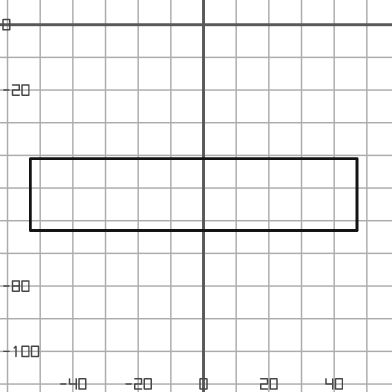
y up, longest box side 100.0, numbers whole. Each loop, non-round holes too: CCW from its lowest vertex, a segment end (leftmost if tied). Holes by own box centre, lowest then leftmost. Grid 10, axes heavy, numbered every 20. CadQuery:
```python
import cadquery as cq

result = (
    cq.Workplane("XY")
    .moveTo(-53.0, -63.0)
    .lineTo(47.0, -63.0)
    .lineTo(47.0, -41.0)
    .lineTo(-53.0, -41.0)
    .close()
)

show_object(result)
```